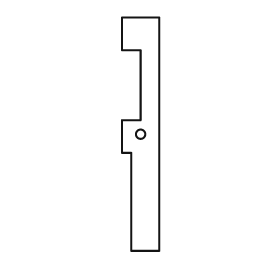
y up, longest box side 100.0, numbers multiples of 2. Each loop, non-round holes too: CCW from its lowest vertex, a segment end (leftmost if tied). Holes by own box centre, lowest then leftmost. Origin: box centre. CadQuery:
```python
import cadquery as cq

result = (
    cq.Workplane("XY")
    .moveTo(-4.0, -50.0)
    .lineTo(8.0, -50.0)
    .lineTo(8.0, 50.0)
    .lineTo(-8.0, 50.0)
    .lineTo(-8.0, 36.0)
    .lineTo(0.0, 36.0)
    .lineTo(0.0, 6.0)
    .lineTo(-8.0, 6.0)
    .lineTo(-8.0, -8.0)
    .lineTo(-4.0, -8.0)
    .close()
    .moveTo(0.0, 0.0)
    .circle(2.0)
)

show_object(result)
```